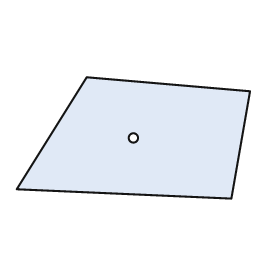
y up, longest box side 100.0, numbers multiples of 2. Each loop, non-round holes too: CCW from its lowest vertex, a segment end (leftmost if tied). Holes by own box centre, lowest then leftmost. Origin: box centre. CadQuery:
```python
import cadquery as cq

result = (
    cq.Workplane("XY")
    .moveTo(42.0, -26.0)
    .lineTo(50.0, 20.0)
    .lineTo(-20.0, 26.0)
    .lineTo(-50.0, -22.0)
    .close()
    .moveTo(0.0, 0.0)
    .circle(2.0)
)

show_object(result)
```